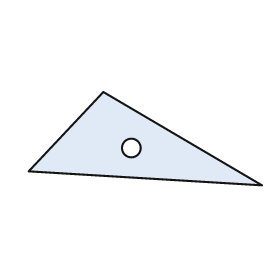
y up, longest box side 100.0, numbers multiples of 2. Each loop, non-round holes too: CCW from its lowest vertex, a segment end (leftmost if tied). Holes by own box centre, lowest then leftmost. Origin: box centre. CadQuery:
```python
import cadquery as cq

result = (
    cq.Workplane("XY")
    .moveTo(50.0, -20.0)
    .lineTo(-18.0, 20.0)
    .lineTo(-50.0, -14.0)
    .close()
    .moveTo(-6.0, -4.0)
    .circle(4.0)
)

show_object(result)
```